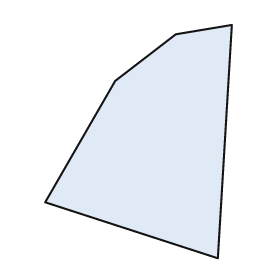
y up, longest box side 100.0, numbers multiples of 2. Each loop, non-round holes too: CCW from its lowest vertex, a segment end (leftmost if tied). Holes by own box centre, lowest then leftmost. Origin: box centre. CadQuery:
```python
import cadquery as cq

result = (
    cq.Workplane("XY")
    .moveTo(34.0, -50.0)
    .lineTo(40.0, 50.0)
    .lineTo(16.0, 46.0)
    .lineTo(-10.0, 26.0)
    .lineTo(-40.0, -26.0)
    .close()
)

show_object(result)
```